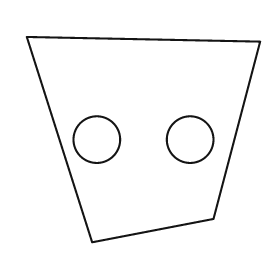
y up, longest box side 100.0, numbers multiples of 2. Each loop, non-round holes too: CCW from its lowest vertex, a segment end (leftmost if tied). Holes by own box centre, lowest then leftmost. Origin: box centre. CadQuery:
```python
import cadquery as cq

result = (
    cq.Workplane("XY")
    .moveTo(-22.0, -44.0)
    .lineTo(30.0, -34.0)
    .lineTo(50.0, 42.0)
    .lineTo(-50.0, 44.0)
    .close()
    .moveTo(-20.0, 0.0)
    .circle(10.0)
    .moveTo(20.0, 0.0)
    .circle(10.0)
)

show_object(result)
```